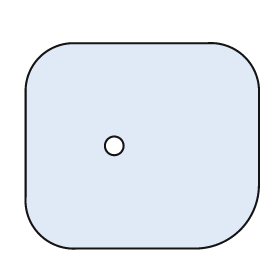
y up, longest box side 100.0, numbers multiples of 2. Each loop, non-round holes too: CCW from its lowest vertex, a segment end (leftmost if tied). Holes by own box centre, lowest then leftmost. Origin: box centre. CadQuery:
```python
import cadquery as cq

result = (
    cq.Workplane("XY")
    .moveTo(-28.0, -44.0)
    .lineTo(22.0, -44.0)
    .threePointArc((42.0, -36.0), (50.0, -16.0))
    .lineTo(50.0, 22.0)
    .threePointArc((44.0, 38.0), (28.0, 44.0))
    .lineTo(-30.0, 44.0)
    .threePointArc((-44.0, 38.0), (-50.0, 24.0))
    .lineTo(-50.0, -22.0)
    .threePointArc((-44.0, -38.0), (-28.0, -44.0))
    .close()
    .moveTo(-12.0, 0.0)
    .circle(4.0)
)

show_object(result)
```